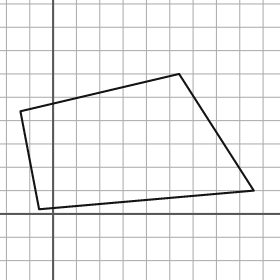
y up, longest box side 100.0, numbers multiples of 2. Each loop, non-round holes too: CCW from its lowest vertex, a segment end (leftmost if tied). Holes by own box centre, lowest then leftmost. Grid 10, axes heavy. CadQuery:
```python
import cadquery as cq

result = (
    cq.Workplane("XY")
    .moveTo(-6.0, 2.0)
    .lineTo(86.0, 10.0)
    .lineTo(54.0, 60.0)
    .lineTo(-14.0, 44.0)
    .close()
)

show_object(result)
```